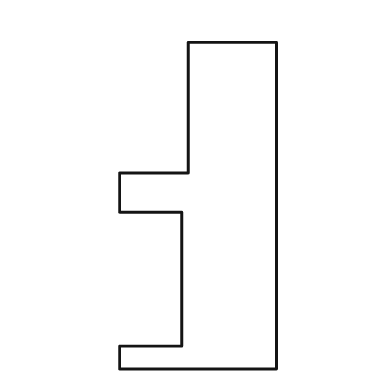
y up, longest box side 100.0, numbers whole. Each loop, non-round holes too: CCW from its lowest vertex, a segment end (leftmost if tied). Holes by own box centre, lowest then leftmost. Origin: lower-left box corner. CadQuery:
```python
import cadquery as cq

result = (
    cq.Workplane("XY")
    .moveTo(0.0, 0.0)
    .lineTo(48.0, 0.0)
    .lineTo(48.0, 100.0)
    .lineTo(21.0, 100.0)
    .lineTo(21.0, 60.0)
    .lineTo(0.0, 60.0)
    .lineTo(0.0, 48.0)
    .lineTo(19.0, 48.0)
    .lineTo(19.0, 7.0)
    .lineTo(0.0, 7.0)
    .close()
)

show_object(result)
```